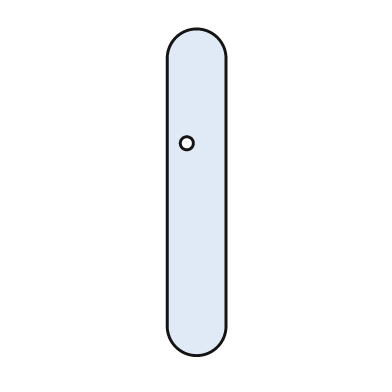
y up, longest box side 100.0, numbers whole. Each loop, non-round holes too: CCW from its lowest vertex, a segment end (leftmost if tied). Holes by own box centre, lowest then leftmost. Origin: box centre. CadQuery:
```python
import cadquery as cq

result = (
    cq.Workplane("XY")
    .moveTo(-9.0, -41.0)
    .threePointArc((0.0, -50.0), (9.0, -41.0))
    .lineTo(9.0, 41.0)
    .threePointArc((0.0, 50.0), (-9.0, 41.0))
    .close()
    .moveTo(-3.0, 15.0)
    .circle(2.0)
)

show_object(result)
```